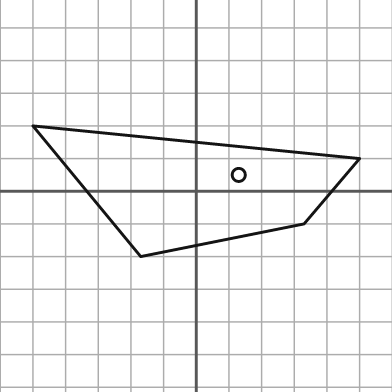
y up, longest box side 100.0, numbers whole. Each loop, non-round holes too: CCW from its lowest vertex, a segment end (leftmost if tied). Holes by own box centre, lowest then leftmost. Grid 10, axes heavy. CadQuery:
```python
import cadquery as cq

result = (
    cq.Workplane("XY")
    .moveTo(-17.0, -20.0)
    .lineTo(33.0, -10.0)
    .lineTo(50.0, 10.0)
    .lineTo(-50.0, 20.0)
    .close()
    .moveTo(13.0, 5.0)
    .circle(2.0)
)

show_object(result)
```